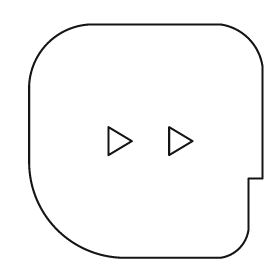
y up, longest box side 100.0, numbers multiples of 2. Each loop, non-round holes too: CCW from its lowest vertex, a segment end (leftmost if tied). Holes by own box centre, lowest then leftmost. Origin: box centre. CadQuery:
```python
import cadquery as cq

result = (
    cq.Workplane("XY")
    .moveTo(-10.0, -50.0)
    .lineTo(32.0, -50.0)
    .threePointArc((40.0, -46.0), (44.0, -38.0))
    .lineTo(44.0, -16.0)
    .lineTo(50.0, -16.0)
    .lineTo(50.0, 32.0)
    .threePointArc((44.0, 44.0), (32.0, 50.0))
    .lineTo(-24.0, 50.0)
    .threePointArc((-42.0, 42.0), (-50.0, 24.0))
    .lineTo(-50.0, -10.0)
    .threePointArc((-38.0, -38.0), (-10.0, -50.0))
    .close()
    .moveTo(-16.0, -6.0)
    .lineTo(-6.0, 0.0)
    .lineTo(-16.0, 6.0)
    .close()
    .moveTo(10.0, -6.0)
    .lineTo(20.0, 0.0)
    .lineTo(10.0, 6.0)
    .close()
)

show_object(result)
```